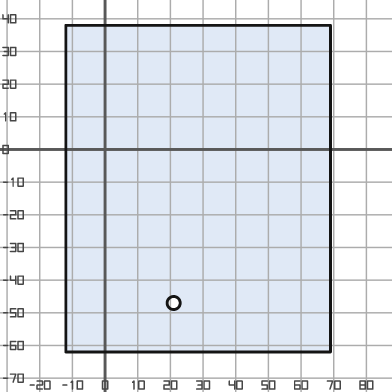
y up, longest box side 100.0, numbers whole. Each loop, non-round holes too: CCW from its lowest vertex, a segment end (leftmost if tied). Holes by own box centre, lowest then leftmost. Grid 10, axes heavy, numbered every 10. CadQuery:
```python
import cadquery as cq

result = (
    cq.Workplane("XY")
    .moveTo(-12.0, -62.0)
    .lineTo(69.0, -62.0)
    .lineTo(69.0, 38.0)
    .lineTo(-12.0, 38.0)
    .close()
    .moveTo(21.0, -47.0)
    .circle(2.0)
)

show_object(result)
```